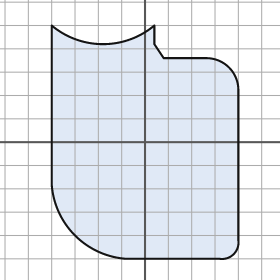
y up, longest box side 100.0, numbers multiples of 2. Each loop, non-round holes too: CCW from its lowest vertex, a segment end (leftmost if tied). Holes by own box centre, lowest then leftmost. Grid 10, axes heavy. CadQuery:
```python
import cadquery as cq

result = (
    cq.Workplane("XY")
    .moveTo(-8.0, -50.0)
    .lineTo(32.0, -50.0)
    .threePointArc((38.0, -48.0), (40.0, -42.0))
    .lineTo(40.0, 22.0)
    .threePointArc((36.0, 32.0), (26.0, 36.0))
    .lineTo(8.0, 36.0)
    .lineTo(4.0, 42.0)
    .lineTo(4.0, 50.0)
    .threePointArc((-18.0, 42.0), (-40.0, 50.0))
    .lineTo(-40.0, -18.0)
    .threePointArc((-30.0, -40.0), (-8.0, -50.0))
    .close()
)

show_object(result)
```